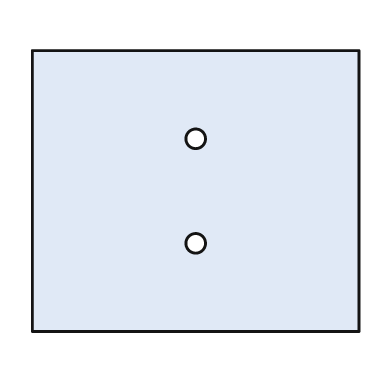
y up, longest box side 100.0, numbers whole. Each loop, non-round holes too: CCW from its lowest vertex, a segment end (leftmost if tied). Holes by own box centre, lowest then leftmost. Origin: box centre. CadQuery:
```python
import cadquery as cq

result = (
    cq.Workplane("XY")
    .moveTo(-50.0, -43.0)
    .lineTo(50.0, -43.0)
    .lineTo(50.0, 43.0)
    .lineTo(-50.0, 43.0)
    .close()
    .moveTo(0.0, -16.0)
    .circle(3.0)
    .moveTo(0.0, 16.0)
    .circle(3.0)
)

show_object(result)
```